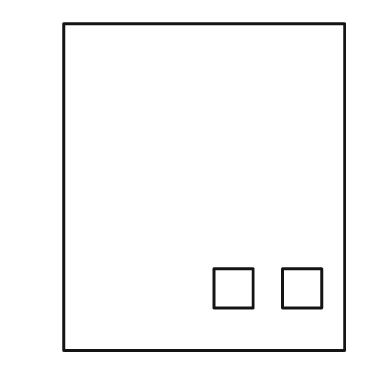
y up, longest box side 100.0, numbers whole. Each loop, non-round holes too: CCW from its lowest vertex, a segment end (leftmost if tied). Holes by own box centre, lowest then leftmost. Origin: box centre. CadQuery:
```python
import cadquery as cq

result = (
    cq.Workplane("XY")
    .moveTo(-43.0, -50.0)
    .lineTo(43.0, -50.0)
    .lineTo(43.0, 50.0)
    .lineTo(-43.0, 50.0)
    .close()
    .moveTo(3.0, -37.0)
    .lineTo(15.0, -37.0)
    .lineTo(15.0, -25.0)
    .lineTo(3.0, -25.0)
    .close()
    .moveTo(24.0, -37.0)
    .lineTo(36.0, -37.0)
    .lineTo(36.0, -25.0)
    .lineTo(24.0, -25.0)
    .close()
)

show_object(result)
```